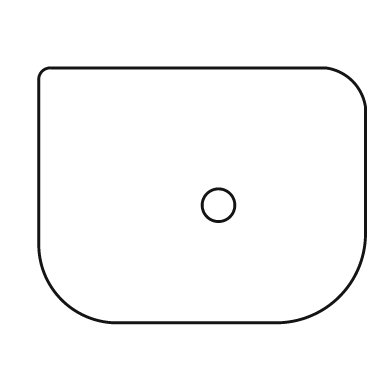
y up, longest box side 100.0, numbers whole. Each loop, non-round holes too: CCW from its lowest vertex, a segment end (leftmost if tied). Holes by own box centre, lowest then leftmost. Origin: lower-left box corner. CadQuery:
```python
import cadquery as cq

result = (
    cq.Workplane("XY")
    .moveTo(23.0, 0.0)
    .lineTo(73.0, 0.0)
    .threePointArc((92.0, 8.0), (100.0, 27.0))
    .lineTo(100.0, 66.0)
    .threePointArc((96.0, 74.0), (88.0, 78.0))
    .lineTo(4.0, 78.0)
    .threePointArc((1.0, 77.0), (0.0, 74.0))
    .lineTo(0.0, 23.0)
    .threePointArc((7.0, 7.0), (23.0, 0.0))
    .close()
    .moveTo(55.0, 36.0)
    .circle(5.0)
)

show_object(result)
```